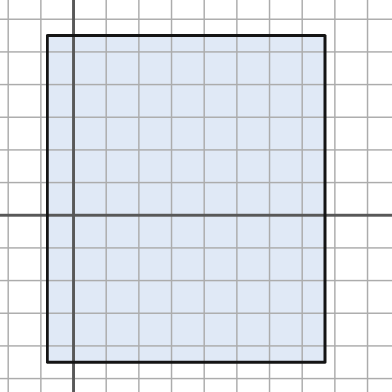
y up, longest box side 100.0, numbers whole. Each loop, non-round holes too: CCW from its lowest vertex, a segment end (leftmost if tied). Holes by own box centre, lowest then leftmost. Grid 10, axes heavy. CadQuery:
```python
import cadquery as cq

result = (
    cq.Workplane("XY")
    .moveTo(-8.0, -45.0)
    .lineTo(77.0, -45.0)
    .lineTo(77.0, 55.0)
    .lineTo(-8.0, 55.0)
    .close()
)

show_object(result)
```